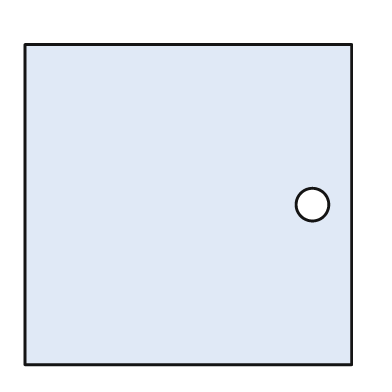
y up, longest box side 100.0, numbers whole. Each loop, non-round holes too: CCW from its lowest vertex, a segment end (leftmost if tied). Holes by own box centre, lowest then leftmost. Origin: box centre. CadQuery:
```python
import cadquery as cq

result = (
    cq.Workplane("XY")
    .moveTo(-50.0, -49.0)
    .lineTo(50.0, -49.0)
    .lineTo(50.0, 49.0)
    .lineTo(-50.0, 49.0)
    .close()
    .moveTo(38.0, 0.0)
    .circle(5.0)
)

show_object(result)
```